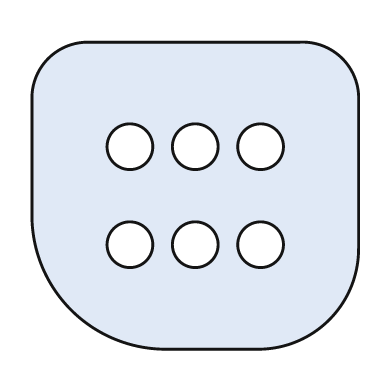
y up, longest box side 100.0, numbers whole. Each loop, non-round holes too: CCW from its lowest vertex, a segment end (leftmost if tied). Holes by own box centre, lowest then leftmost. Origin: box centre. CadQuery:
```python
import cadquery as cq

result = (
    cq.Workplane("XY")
    .moveTo(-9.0, -47.0)
    .lineTo(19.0, -47.0)
    .threePointArc((41.0, -38.0), (50.0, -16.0))
    .lineTo(50.0, 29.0)
    .threePointArc((45.0, 42.0), (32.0, 47.0))
    .lineTo(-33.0, 47.0)
    .threePointArc((-45.0, 42.0), (-50.0, 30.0))
    .lineTo(-50.0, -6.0)
    .threePointArc((-38.0, -35.0), (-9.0, -47.0))
    .close()
    .moveTo(-20.0, -15.0)
    .circle(7.0)
    .moveTo(0.0, -15.0)
    .circle(7.0)
    .moveTo(20.0, -15.0)
    .circle(7.0)
    .moveTo(-20.0, 15.0)
    .circle(7.0)
    .moveTo(0.0, 15.0)
    .circle(7.0)
    .moveTo(20.0, 15.0)
    .circle(7.0)
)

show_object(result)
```